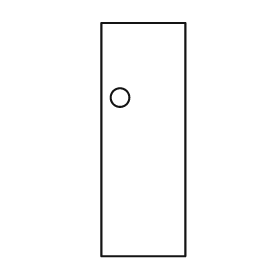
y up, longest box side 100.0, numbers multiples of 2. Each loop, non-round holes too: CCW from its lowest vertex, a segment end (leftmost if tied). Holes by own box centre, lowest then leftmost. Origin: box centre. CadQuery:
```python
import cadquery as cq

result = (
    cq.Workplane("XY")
    .moveTo(-18.0, -50.0)
    .lineTo(18.0, -50.0)
    .lineTo(18.0, 50.0)
    .lineTo(-18.0, 50.0)
    .close()
    .moveTo(-10.0, 18.0)
    .circle(4.0)
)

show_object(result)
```